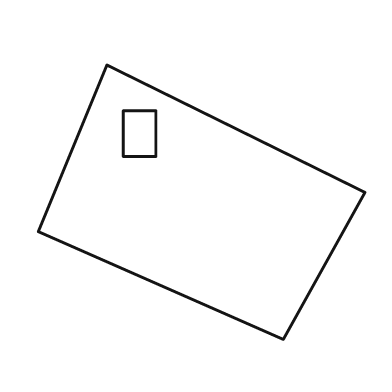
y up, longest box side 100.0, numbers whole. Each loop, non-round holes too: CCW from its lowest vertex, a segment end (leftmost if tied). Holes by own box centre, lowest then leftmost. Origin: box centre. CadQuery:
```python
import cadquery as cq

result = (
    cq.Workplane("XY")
    .moveTo(25.0, -42.0)
    .lineTo(50.0, 3.0)
    .lineTo(-29.0, 42.0)
    .lineTo(-50.0, -9.0)
    .close()
    .moveTo(-24.0, 14.0)
    .lineTo(-14.0, 14.0)
    .lineTo(-14.0, 28.0)
    .lineTo(-24.0, 28.0)
    .close()
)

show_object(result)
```